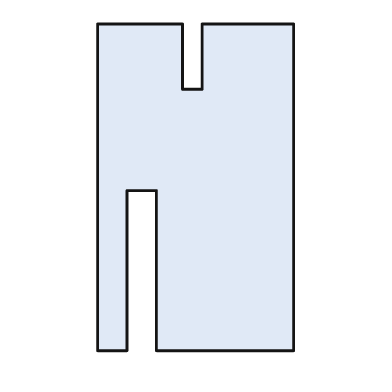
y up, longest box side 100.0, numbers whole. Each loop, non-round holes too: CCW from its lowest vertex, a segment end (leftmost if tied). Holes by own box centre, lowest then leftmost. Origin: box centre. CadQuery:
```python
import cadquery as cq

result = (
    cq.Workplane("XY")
    .moveTo(-30.0, -50.0)
    .lineTo(-21.0, -50.0)
    .lineTo(-21.0, -1.0)
    .lineTo(-12.0, -1.0)
    .lineTo(-12.0, -50.0)
    .lineTo(30.0, -50.0)
    .lineTo(30.0, 50.0)
    .lineTo(2.0, 50.0)
    .lineTo(2.0, 30.0)
    .lineTo(-4.0, 30.0)
    .lineTo(-4.0, 50.0)
    .lineTo(-30.0, 50.0)
    .close()
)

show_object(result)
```